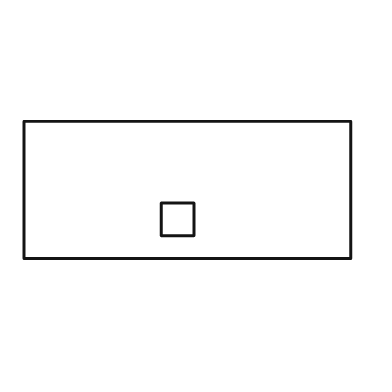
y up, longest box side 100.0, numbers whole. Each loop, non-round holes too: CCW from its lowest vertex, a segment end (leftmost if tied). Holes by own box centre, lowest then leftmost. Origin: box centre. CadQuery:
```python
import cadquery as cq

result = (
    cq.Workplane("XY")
    .moveTo(-50.0, -21.0)
    .lineTo(50.0, -21.0)
    .lineTo(50.0, 21.0)
    .lineTo(-50.0, 21.0)
    .close()
    .moveTo(-8.0, -14.0)
    .lineTo(2.0, -14.0)
    .lineTo(2.0, -4.0)
    .lineTo(-8.0, -4.0)
    .close()
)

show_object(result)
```